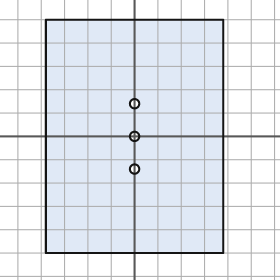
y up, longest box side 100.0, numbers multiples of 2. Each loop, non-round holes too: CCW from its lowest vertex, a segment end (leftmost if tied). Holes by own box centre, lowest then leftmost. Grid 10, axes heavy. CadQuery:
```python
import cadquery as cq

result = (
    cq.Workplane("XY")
    .moveTo(-38.0, -50.0)
    .lineTo(38.0, -50.0)
    .lineTo(38.0, 50.0)
    .lineTo(-38.0, 50.0)
    .close()
    .moveTo(0.0, -14.0)
    .circle(2.0)
    .moveTo(0.0, 0.0)
    .circle(2.0)
    .moveTo(0.0, 14.0)
    .circle(2.0)
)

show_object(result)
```